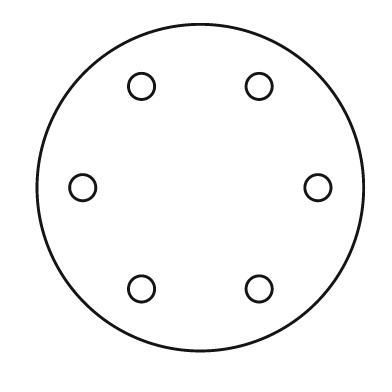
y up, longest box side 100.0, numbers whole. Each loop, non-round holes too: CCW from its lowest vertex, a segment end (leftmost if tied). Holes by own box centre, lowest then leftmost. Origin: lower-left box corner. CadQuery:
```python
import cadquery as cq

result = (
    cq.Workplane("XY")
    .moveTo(50.0, 50.0)
    .circle(50.0)
    .moveTo(32.0, 19.0)
    .circle(4.0)
    .moveTo(68.0, 19.0)
    .circle(4.0)
    .moveTo(14.0, 50.0)
    .circle(4.0)
    .moveTo(86.0, 50.0)
    .circle(4.0)
    .moveTo(32.0, 81.0)
    .circle(4.0)
    .moveTo(68.0, 81.0)
    .circle(4.0)
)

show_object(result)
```